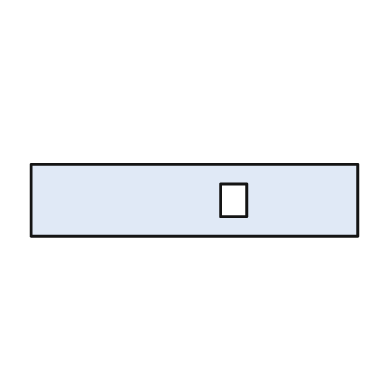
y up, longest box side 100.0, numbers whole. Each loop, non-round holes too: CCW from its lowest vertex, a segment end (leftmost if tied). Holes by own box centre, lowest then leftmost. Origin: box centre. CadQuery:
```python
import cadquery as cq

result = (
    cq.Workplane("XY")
    .moveTo(-50.0, -11.0)
    .lineTo(50.0, -11.0)
    .lineTo(50.0, 11.0)
    .lineTo(-50.0, 11.0)
    .close()
    .moveTo(8.0, -5.0)
    .lineTo(16.0, -5.0)
    .lineTo(16.0, 5.0)
    .lineTo(8.0, 5.0)
    .close()
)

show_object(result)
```